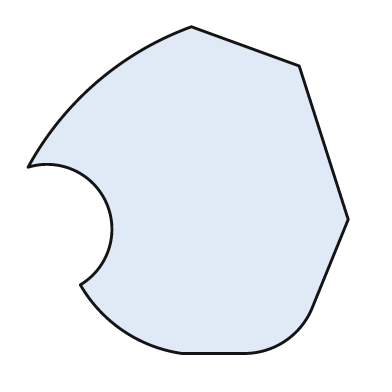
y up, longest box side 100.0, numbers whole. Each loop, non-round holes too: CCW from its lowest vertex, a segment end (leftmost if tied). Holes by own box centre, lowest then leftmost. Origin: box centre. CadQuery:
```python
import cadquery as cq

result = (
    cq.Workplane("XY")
    .moveTo(-2.0, -50.0)
    .lineTo(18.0, -50.0)
    .threePointArc((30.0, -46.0), (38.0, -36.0))
    .lineTo(49.0, -9.0)
    .lineTo(34.0, 38.0)
    .lineTo(1.0, 50.0)
    .threePointArc((-28.0, 33.0), (-49.0, 7.0))
    .threePointArc((-25.0, -4.0), (-33.0, -29.0))
    .threePointArc((-20.0, -43.0), (-2.0, -50.0))
    .close()
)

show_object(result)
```